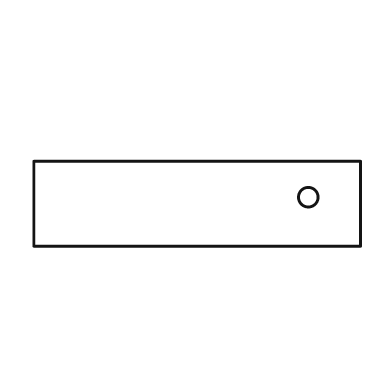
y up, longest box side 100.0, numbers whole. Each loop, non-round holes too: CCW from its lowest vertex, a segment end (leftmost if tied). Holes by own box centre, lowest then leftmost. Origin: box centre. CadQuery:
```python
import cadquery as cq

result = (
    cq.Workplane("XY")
    .moveTo(-50.0, -13.0)
    .lineTo(50.0, -13.0)
    .lineTo(50.0, 13.0)
    .lineTo(-50.0, 13.0)
    .close()
    .moveTo(34.0, 2.0)
    .circle(3.0)
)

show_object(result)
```